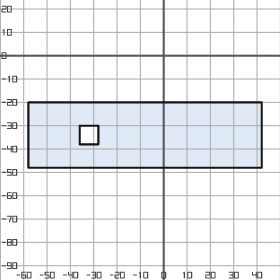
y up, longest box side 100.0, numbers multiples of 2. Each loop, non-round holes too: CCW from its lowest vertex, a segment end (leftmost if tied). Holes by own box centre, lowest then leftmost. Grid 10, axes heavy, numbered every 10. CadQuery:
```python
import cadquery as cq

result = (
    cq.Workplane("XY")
    .moveTo(-58.0, -48.0)
    .lineTo(42.0, -48.0)
    .lineTo(42.0, -20.0)
    .lineTo(-58.0, -20.0)
    .close()
    .moveTo(-36.0, -38.0)
    .lineTo(-28.0, -38.0)
    .lineTo(-28.0, -30.0)
    .lineTo(-36.0, -30.0)
    .close()
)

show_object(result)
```